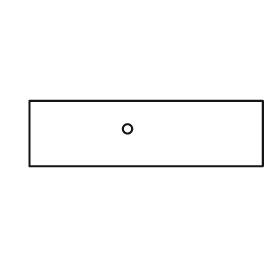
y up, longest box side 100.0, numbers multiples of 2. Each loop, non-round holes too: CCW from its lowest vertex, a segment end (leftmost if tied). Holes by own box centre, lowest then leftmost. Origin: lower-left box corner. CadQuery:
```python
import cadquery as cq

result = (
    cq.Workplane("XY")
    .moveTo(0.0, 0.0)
    .lineTo(100.0, 0.0)
    .lineTo(100.0, 28.0)
    .lineTo(0.0, 28.0)
    .close()
    .moveTo(42.0, 16.0)
    .circle(2.0)
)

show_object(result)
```